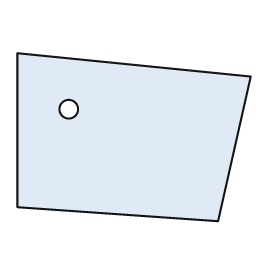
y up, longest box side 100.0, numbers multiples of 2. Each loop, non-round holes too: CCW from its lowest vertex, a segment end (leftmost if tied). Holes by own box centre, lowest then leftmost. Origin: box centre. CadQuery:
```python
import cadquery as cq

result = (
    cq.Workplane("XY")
    .moveTo(36.0, -36.0)
    .lineTo(50.0, 26.0)
    .lineTo(-50.0, 36.0)
    .lineTo(-50.0, -30.0)
    .close()
    .moveTo(-28.0, 12.0)
    .circle(4.0)
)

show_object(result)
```